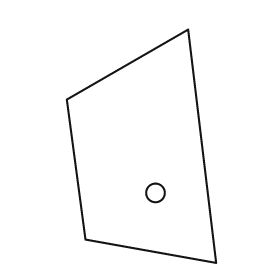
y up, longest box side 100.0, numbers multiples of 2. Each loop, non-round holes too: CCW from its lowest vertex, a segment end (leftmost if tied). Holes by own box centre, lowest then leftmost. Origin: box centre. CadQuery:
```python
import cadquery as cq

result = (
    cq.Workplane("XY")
    .moveTo(32.0, -50.0)
    .lineTo(20.0, 50.0)
    .lineTo(-32.0, 20.0)
    .lineTo(-24.0, -40.0)
    .close()
    .moveTo(6.0, -20.0)
    .circle(4.0)
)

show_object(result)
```